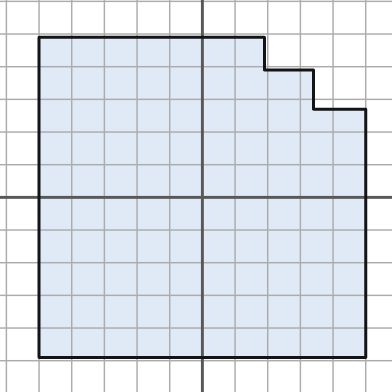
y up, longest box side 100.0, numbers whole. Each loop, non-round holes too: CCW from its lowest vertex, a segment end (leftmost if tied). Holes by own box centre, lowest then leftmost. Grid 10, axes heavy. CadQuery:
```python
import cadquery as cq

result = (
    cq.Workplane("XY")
    .moveTo(-50.0, -49.0)
    .lineTo(50.0, -49.0)
    .lineTo(50.0, 27.0)
    .lineTo(34.0, 27.0)
    .lineTo(34.0, 39.0)
    .lineTo(19.0, 39.0)
    .lineTo(19.0, 49.0)
    .lineTo(-50.0, 49.0)
    .close()
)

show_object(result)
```